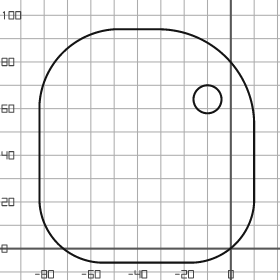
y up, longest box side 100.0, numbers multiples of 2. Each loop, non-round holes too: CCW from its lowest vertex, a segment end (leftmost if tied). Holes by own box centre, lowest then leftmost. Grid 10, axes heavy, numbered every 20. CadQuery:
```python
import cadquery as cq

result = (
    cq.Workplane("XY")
    .moveTo(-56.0, -6.0)
    .lineTo(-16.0, -6.0)
    .threePointArc((2.0, 2.0), (10.0, 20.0))
    .lineTo(10.0, 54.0)
    .threePointArc((-2.0, 82.0), (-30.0, 94.0))
    .lineTo(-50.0, 94.0)
    .threePointArc((-72.0, 84.0), (-82.0, 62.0))
    .lineTo(-82.0, 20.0)
    .threePointArc((-74.0, 2.0), (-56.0, -6.0))
    .close()
    .moveTo(-10.0, 64.0)
    .circle(6.0)
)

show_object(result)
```